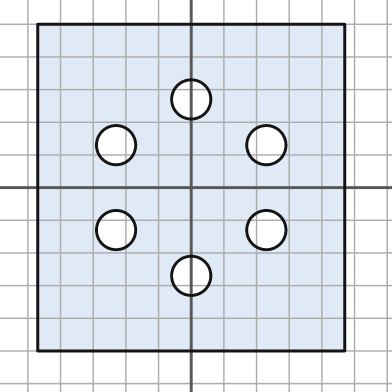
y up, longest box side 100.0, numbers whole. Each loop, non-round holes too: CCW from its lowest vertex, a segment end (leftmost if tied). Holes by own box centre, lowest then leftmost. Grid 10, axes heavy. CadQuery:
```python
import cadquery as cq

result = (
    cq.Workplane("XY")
    .moveTo(-47.0, -50.0)
    .lineTo(47.0, -50.0)
    .lineTo(47.0, 50.0)
    .lineTo(-47.0, 50.0)
    .close()
    .moveTo(0.0, -27.0)
    .circle(6.0)
    .moveTo(-23.0, -13.0)
    .circle(6.0)
    .moveTo(23.0, -13.0)
    .circle(6.0)
    .moveTo(-23.0, 13.0)
    .circle(6.0)
    .moveTo(23.0, 13.0)
    .circle(6.0)
    .moveTo(0.0, 27.0)
    .circle(6.0)
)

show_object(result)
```